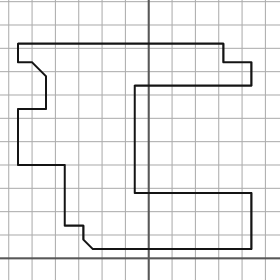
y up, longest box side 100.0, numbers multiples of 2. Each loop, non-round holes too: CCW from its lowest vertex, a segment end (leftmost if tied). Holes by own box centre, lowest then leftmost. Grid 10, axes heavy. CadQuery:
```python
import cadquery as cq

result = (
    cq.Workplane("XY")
    .moveTo(-24.0, 4.0)
    .lineTo(44.0, 4.0)
    .lineTo(44.0, 28.0)
    .lineTo(-6.0, 28.0)
    .lineTo(-6.0, 74.0)
    .lineTo(44.0, 74.0)
    .lineTo(44.0, 84.0)
    .lineTo(32.0, 84.0)
    .lineTo(32.0, 92.0)
    .lineTo(-56.0, 92.0)
    .lineTo(-56.0, 84.0)
    .lineTo(-50.0, 84.0)
    .lineTo(-44.0, 78.0)
    .lineTo(-44.0, 64.0)
    .lineTo(-56.0, 64.0)
    .lineTo(-56.0, 40.0)
    .lineTo(-36.0, 40.0)
    .lineTo(-36.0, 14.0)
    .lineTo(-28.0, 14.0)
    .lineTo(-28.0, 8.0)
    .close()
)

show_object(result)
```